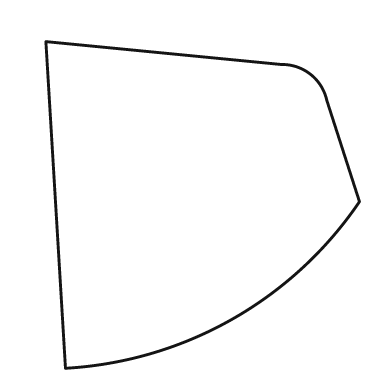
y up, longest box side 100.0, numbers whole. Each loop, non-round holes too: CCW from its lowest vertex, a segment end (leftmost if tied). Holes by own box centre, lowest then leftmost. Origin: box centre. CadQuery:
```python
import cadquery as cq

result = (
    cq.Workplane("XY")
    .moveTo(-42.0, -50.0)
    .threePointArc((9.0, -35.0), (48.0, 1.0))
    .lineTo(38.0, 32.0)
    .threePointArc((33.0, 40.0), (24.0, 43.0))
    .lineTo(-48.0, 50.0)
    .close()
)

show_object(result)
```